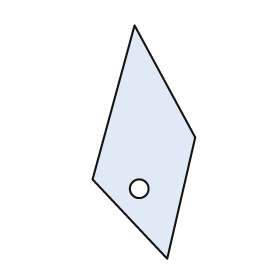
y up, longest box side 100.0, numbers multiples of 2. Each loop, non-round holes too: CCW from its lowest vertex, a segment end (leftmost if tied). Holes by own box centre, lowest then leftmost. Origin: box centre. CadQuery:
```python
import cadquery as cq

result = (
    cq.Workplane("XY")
    .moveTo(10.0, -50.0)
    .lineTo(22.0, 2.0)
    .lineTo(-4.0, 50.0)
    .lineTo(-22.0, -16.0)
    .close()
    .moveTo(-2.0, -20.0)
    .circle(4.0)
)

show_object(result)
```